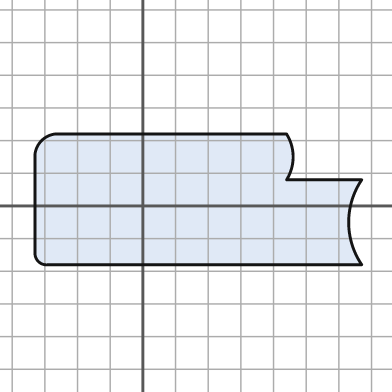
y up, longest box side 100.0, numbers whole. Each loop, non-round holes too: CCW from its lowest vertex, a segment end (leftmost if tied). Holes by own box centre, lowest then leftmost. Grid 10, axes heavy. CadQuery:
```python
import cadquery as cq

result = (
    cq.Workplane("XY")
    .moveTo(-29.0, -18.0)
    .lineTo(67.0, -18.0)
    .threePointArc((63.0, -5.0), (67.0, 8.0))
    .lineTo(44.0, 8.0)
    .threePointArc((46.0, 15.0), (44.0, 22.0))
    .lineTo(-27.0, 22.0)
    .threePointArc((-31.0, 20.0), (-33.0, 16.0))
    .lineTo(-33.0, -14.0)
    .threePointArc((-32.0, -17.0), (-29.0, -18.0))
    .close()
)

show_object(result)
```